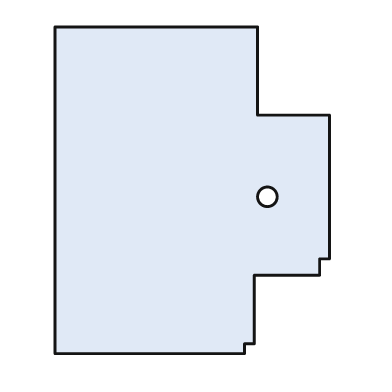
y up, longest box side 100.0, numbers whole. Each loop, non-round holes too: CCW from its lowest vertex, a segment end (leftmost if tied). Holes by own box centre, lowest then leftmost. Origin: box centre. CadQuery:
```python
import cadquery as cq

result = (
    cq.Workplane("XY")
    .moveTo(-42.0, -50.0)
    .lineTo(16.0, -50.0)
    .lineTo(16.0, -47.0)
    .lineTo(19.0, -47.0)
    .lineTo(19.0, -26.0)
    .lineTo(39.0, -26.0)
    .lineTo(39.0, -21.0)
    .lineTo(42.0, -21.0)
    .lineTo(42.0, 23.0)
    .lineTo(20.0, 23.0)
    .lineTo(20.0, 50.0)
    .lineTo(-42.0, 50.0)
    .close()
    .moveTo(23.0, -2.0)
    .circle(3.0)
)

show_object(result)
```